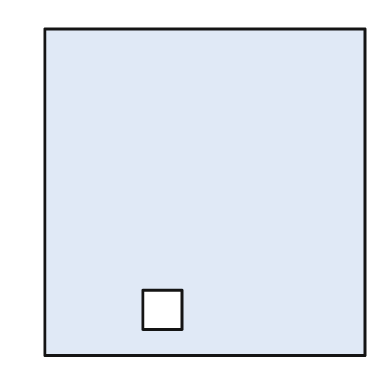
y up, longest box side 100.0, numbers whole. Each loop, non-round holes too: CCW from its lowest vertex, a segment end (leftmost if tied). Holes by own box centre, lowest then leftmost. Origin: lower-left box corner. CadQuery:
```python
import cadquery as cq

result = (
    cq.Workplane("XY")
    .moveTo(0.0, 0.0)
    .lineTo(98.0, 0.0)
    .lineTo(98.0, 100.0)
    .lineTo(0.0, 100.0)
    .close()
    .moveTo(30.0, 8.0)
    .lineTo(42.0, 8.0)
    .lineTo(42.0, 20.0)
    .lineTo(30.0, 20.0)
    .close()
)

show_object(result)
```